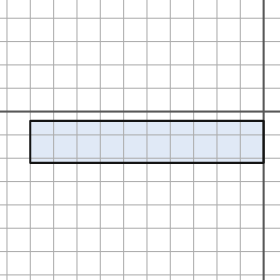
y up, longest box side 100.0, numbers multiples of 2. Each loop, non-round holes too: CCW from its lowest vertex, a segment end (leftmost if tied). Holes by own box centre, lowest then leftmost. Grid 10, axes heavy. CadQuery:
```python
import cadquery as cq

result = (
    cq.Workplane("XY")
    .moveTo(-100.0, -22.0)
    .lineTo(0.0, -22.0)
    .lineTo(0.0, -4.0)
    .lineTo(-100.0, -4.0)
    .close()
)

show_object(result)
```